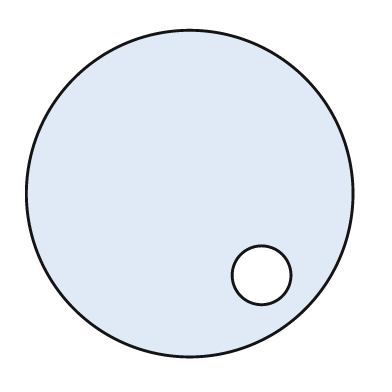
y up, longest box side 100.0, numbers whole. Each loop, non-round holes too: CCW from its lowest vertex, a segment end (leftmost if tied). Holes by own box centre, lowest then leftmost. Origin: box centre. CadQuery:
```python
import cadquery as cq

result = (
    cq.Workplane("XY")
    .moveTo(0.0, 0.0)
    .circle(50.0)
    .moveTo(22.0, -25.0)
    .circle(9.0)
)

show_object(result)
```